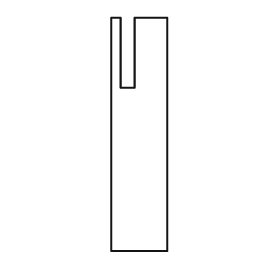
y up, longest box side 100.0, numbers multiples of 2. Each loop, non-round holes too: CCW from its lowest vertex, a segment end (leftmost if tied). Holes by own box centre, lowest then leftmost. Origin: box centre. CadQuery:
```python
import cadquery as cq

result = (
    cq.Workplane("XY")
    .moveTo(-12.0, -50.0)
    .lineTo(12.0, -50.0)
    .lineTo(12.0, 50.0)
    .lineTo(-2.0, 50.0)
    .lineTo(-2.0, 20.0)
    .lineTo(-8.0, 20.0)
    .lineTo(-8.0, 50.0)
    .lineTo(-12.0, 50.0)
    .close()
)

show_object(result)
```